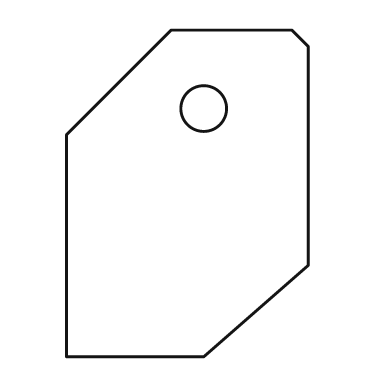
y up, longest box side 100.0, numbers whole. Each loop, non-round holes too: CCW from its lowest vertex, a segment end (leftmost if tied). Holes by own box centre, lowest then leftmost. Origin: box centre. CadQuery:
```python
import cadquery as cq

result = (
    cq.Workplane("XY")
    .moveTo(-37.0, -50.0)
    .lineTo(5.0, -50.0)
    .lineTo(37.0, -22.0)
    .lineTo(37.0, 45.0)
    .lineTo(32.0, 50.0)
    .lineTo(-5.0, 50.0)
    .lineTo(-37.0, 18.0)
    .close()
    .moveTo(5.0, 26.0)
    .circle(7.0)
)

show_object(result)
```